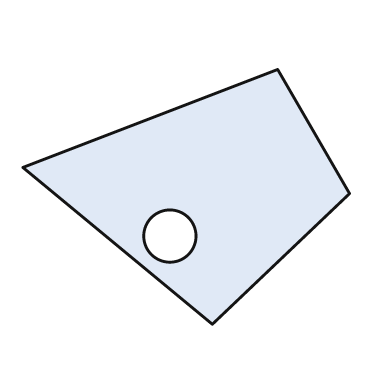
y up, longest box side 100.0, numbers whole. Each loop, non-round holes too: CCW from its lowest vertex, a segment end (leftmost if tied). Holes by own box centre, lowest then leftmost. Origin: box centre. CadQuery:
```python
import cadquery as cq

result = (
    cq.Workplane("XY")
    .moveTo(8.0, -39.0)
    .lineTo(50.0, 1.0)
    .lineTo(28.0, 39.0)
    .lineTo(-50.0, 9.0)
    .close()
    .moveTo(-5.0, -12.0)
    .circle(8.0)
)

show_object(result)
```